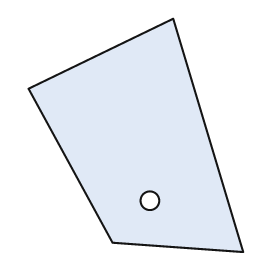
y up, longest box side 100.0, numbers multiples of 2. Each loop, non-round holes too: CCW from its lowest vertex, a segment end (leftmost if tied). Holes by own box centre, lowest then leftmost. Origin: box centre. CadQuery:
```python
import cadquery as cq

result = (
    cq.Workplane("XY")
    .moveTo(46.0, -50.0)
    .lineTo(16.0, 50.0)
    .lineTo(-46.0, 20.0)
    .lineTo(-10.0, -46.0)
    .close()
    .moveTo(6.0, -28.0)
    .circle(4.0)
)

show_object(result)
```